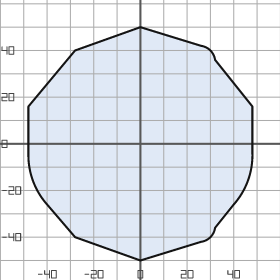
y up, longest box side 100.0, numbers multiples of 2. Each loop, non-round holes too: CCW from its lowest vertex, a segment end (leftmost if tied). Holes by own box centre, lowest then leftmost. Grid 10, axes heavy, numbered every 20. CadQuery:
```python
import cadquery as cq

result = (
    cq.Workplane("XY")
    .moveTo(0.0, -50.0)
    .lineTo(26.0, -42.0)
    .threePointArc((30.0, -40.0), (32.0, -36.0))
    .lineTo(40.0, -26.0)
    .threePointArc((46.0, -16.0), (48.0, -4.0))
    .lineTo(48.0, 16.0)
    .lineTo(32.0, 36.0)
    .threePointArc((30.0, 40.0), (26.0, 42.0))
    .lineTo(0.0, 50.0)
    .lineTo(-28.0, 40.0)
    .lineTo(-48.0, 16.0)
    .lineTo(-48.0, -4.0)
    .threePointArc((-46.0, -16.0), (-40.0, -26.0))
    .lineTo(-28.0, -40.0)
    .close()
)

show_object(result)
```